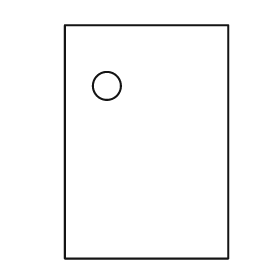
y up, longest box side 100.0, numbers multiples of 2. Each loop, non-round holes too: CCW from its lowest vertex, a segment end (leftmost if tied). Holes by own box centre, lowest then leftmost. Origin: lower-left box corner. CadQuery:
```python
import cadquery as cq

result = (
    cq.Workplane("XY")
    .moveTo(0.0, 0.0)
    .lineTo(70.0, 0.0)
    .lineTo(70.0, 100.0)
    .lineTo(0.0, 100.0)
    .close()
    .moveTo(18.0, 74.0)
    .circle(6.0)
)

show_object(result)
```